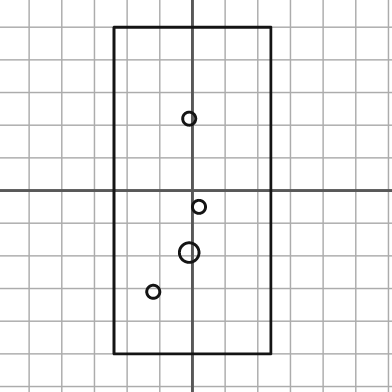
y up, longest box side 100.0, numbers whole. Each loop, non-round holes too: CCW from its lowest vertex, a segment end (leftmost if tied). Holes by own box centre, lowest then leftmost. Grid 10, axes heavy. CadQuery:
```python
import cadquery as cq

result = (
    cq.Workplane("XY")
    .moveTo(-24.0, -50.0)
    .lineTo(24.0, -50.0)
    .lineTo(24.0, 50.0)
    .lineTo(-24.0, 50.0)
    .close()
    .moveTo(-12.0, -31.0)
    .circle(2.0)
    .moveTo(-1.0, -19.0)
    .circle(3.0)
    .moveTo(2.0, -5.0)
    .circle(2.0)
    .moveTo(-1.0, 22.0)
    .circle(2.0)
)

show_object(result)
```